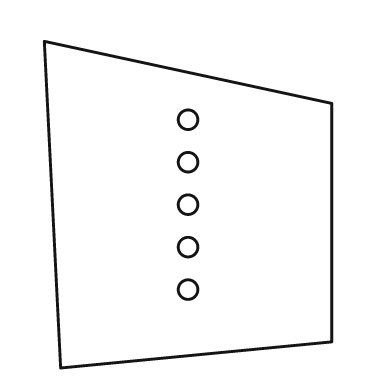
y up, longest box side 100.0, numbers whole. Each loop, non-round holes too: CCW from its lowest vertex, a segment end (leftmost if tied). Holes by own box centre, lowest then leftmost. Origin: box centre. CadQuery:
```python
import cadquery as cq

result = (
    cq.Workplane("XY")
    .moveTo(-39.0, -50.0)
    .lineTo(44.0, -42.0)
    .lineTo(44.0, 31.0)
    .lineTo(-44.0, 50.0)
    .close()
    .moveTo(0.0, -26.0)
    .circle(3.0)
    .moveTo(0.0, -13.0)
    .circle(3.0)
    .moveTo(0.0, 0.0)
    .circle(3.0)
    .moveTo(0.0, 13.0)
    .circle(3.0)
    .moveTo(0.0, 26.0)
    .circle(3.0)
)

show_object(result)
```